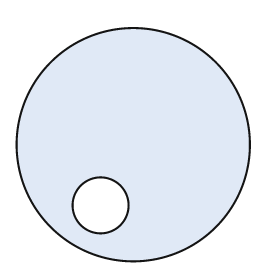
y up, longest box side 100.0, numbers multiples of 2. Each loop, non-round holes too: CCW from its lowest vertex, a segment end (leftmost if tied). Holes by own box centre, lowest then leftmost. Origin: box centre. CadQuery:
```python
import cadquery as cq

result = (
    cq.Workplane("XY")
    .moveTo(0.0, 0.0)
    .circle(50.0)
    .moveTo(-14.0, -26.0)
    .circle(12.0)
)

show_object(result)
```